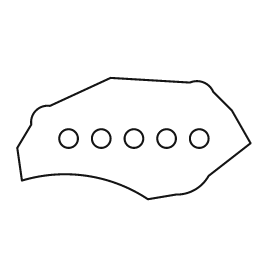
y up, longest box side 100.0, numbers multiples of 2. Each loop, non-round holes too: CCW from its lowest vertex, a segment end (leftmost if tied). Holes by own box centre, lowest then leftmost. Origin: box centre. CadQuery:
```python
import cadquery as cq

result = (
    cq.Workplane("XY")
    .moveTo(6.0, -26.0)
    .lineTo(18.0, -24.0)
    .threePointArc((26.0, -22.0), (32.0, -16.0))
    .lineTo(50.0, -2.0)
    .lineTo(42.0, 12.0)
    .lineTo(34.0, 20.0)
    .threePointArc((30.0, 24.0), (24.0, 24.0))
    .lineTo(-10.0, 26.0)
    .lineTo(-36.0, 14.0)
    .threePointArc((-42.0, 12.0), (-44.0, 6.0))
    .lineTo(-50.0, -4.0)
    .lineTo(-48.0, -18.0)
    .threePointArc((-20.0, -16.0), (6.0, -26.0))
    .close()
    .moveTo(-28.0, 0.0)
    .circle(4.0)
    .moveTo(-14.0, 0.0)
    .circle(4.0)
    .moveTo(0.0, 0.0)
    .circle(4.0)
    .moveTo(14.0, 0.0)
    .circle(4.0)
    .moveTo(28.0, 0.0)
    .circle(4.0)
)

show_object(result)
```